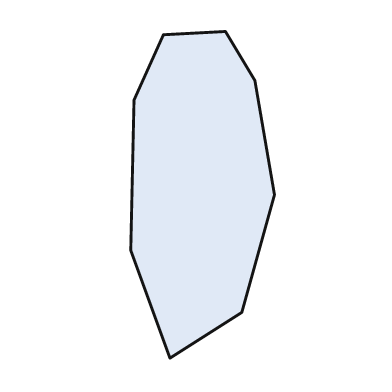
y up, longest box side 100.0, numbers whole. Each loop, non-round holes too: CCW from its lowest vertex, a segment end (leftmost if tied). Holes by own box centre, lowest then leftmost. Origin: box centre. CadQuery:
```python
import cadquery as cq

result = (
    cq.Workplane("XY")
    .moveTo(-10.0, -50.0)
    .lineTo(12.0, -36.0)
    .lineTo(22.0, 0.0)
    .lineTo(16.0, 35.0)
    .lineTo(7.0, 50.0)
    .lineTo(-12.0, 49.0)
    .lineTo(-21.0, 29.0)
    .lineTo(-22.0, -17.0)
    .close()
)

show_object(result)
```